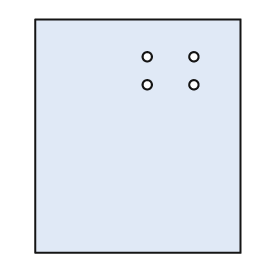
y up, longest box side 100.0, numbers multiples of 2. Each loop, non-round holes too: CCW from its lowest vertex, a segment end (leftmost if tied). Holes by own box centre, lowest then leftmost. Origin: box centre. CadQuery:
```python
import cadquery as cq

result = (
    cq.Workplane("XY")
    .moveTo(-44.0, -50.0)
    .lineTo(44.0, -50.0)
    .lineTo(44.0, 50.0)
    .lineTo(-44.0, 50.0)
    .close()
    .moveTo(4.0, 22.0)
    .circle(2.0)
    .moveTo(24.0, 22.0)
    .circle(2.0)
    .moveTo(4.0, 34.0)
    .circle(2.0)
    .moveTo(24.0, 34.0)
    .circle(2.0)
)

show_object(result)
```